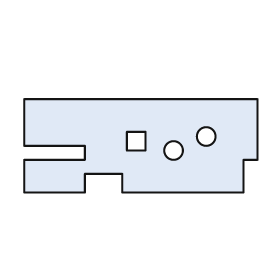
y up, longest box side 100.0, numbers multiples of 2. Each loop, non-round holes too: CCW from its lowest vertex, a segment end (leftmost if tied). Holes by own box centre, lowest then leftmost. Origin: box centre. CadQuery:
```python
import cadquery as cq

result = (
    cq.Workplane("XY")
    .moveTo(-50.0, -20.0)
    .lineTo(-24.0, -20.0)
    .lineTo(-24.0, -12.0)
    .lineTo(-8.0, -12.0)
    .lineTo(-8.0, -20.0)
    .lineTo(44.0, -20.0)
    .lineTo(44.0, -6.0)
    .lineTo(50.0, -6.0)
    .lineTo(50.0, 20.0)
    .lineTo(-50.0, 20.0)
    .lineTo(-50.0, 0.0)
    .lineTo(-24.0, 0.0)
    .lineTo(-24.0, -6.0)
    .lineTo(-50.0, -6.0)
    .close()
    .moveTo(14.0, -2.0)
    .circle(4.0)
    .moveTo(-6.0, -2.0)
    .lineTo(2.0, -2.0)
    .lineTo(2.0, 6.0)
    .lineTo(-6.0, 6.0)
    .close()
    .moveTo(28.0, 4.0)
    .circle(4.0)
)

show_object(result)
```